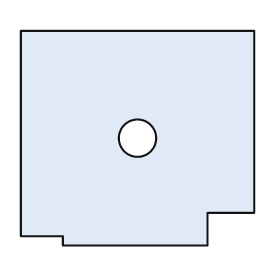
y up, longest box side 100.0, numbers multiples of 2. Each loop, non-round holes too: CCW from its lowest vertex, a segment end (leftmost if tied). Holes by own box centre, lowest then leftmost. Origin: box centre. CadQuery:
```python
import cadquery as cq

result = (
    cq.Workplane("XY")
    .moveTo(-32.0, -46.0)
    .lineTo(30.0, -46.0)
    .lineTo(30.0, -32.0)
    .lineTo(50.0, -32.0)
    .lineTo(50.0, 46.0)
    .lineTo(-50.0, 46.0)
    .lineTo(-50.0, -42.0)
    .lineTo(-32.0, -42.0)
    .close()
    .moveTo(0.0, 0.0)
    .circle(8.0)
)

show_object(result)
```